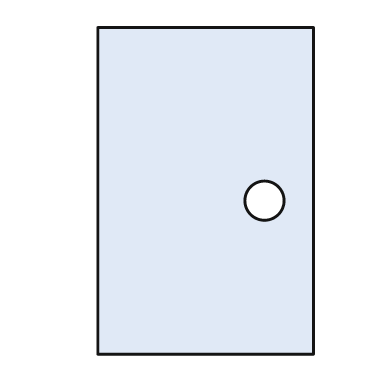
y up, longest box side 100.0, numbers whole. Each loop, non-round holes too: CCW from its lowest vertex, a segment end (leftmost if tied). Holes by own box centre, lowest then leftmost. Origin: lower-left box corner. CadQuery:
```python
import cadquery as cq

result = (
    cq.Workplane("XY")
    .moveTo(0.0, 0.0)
    .lineTo(66.0, 0.0)
    .lineTo(66.0, 100.0)
    .lineTo(0.0, 100.0)
    .close()
    .moveTo(51.0, 47.0)
    .circle(6.0)
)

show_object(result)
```